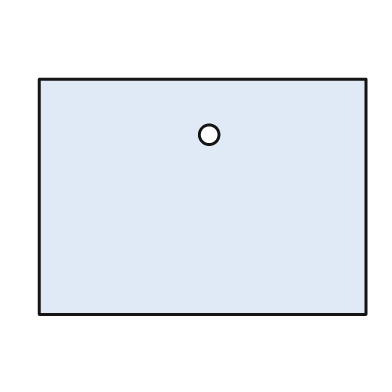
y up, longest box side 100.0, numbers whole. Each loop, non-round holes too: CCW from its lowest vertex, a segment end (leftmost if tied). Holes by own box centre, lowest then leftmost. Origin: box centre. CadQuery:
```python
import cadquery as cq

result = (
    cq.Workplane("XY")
    .moveTo(-50.0, -36.0)
    .lineTo(50.0, -36.0)
    .lineTo(50.0, 36.0)
    .lineTo(-50.0, 36.0)
    .close()
    .moveTo(2.0, 19.0)
    .circle(3.0)
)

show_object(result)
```